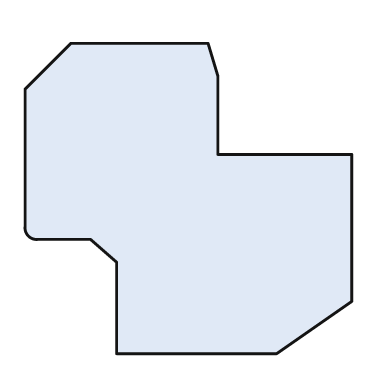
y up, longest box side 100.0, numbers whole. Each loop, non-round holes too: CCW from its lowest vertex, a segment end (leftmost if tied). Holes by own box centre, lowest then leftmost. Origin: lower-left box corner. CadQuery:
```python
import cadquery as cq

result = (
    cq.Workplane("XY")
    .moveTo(28.0, 0.0)
    .lineTo(77.0, 0.0)
    .lineTo(100.0, 16.0)
    .lineTo(100.0, 61.0)
    .lineTo(59.0, 61.0)
    .lineTo(59.0, 85.0)
    .lineTo(56.0, 95.0)
    .lineTo(14.0, 95.0)
    .lineTo(0.0, 81.0)
    .lineTo(0.0, 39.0)
    .threePointArc((1.0, 36.0), (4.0, 35.0))
    .lineTo(20.0, 35.0)
    .lineTo(28.0, 28.0)
    .close()
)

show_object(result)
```